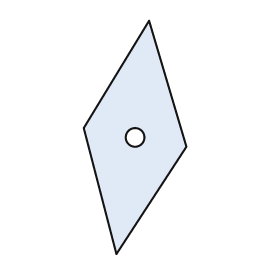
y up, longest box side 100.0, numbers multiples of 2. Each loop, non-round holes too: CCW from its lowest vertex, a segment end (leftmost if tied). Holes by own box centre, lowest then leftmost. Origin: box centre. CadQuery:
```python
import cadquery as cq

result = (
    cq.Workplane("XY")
    .moveTo(-8.0, -50.0)
    .lineTo(22.0, -4.0)
    .lineTo(6.0, 50.0)
    .lineTo(-22.0, 4.0)
    .close()
    .moveTo(0.0, 0.0)
    .circle(4.0)
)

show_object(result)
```